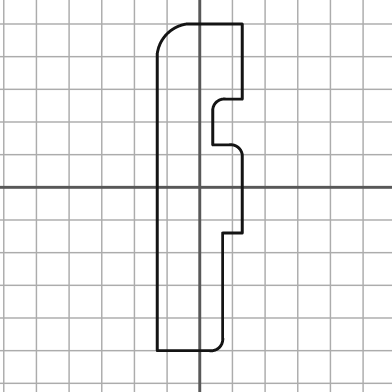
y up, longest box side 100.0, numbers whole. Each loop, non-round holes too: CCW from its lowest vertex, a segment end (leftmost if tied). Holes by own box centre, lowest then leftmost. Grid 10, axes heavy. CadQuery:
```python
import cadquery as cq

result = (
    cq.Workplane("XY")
    .moveTo(-13.0, -50.0)
    .lineTo(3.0, -50.0)
    .threePointArc((6.0, -49.0), (7.0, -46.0))
    .lineTo(7.0, -14.0)
    .lineTo(13.0, -14.0)
    .lineTo(13.0, 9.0)
    .threePointArc((12.0, 12.0), (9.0, 13.0))
    .lineTo(4.0, 13.0)
    .lineTo(4.0, 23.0)
    .threePointArc((5.0, 26.0), (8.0, 27.0))
    .lineTo(13.0, 27.0)
    .lineTo(13.0, 50.0)
    .lineTo(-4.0, 50.0)
    .threePointArc((-10.0, 47.0), (-13.0, 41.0))
    .close()
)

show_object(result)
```